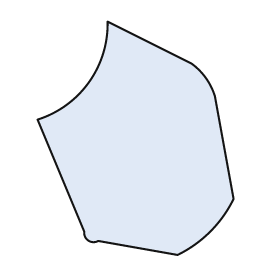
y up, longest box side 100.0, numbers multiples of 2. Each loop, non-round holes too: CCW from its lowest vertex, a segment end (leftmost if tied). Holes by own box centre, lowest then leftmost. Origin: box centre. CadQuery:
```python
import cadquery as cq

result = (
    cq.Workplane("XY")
    .moveTo(18.0, -50.0)
    .threePointArc((32.0, -40.0), (42.0, -26.0))
    .lineTo(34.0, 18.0)
    .threePointArc((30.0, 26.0), (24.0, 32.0))
    .lineTo(-12.0, 50.0)
    .threePointArc((-20.0, 24.0), (-42.0, 8.0))
    .lineTo(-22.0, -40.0)
    .threePointArc((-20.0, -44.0), (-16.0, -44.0))
    .close()
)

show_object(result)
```